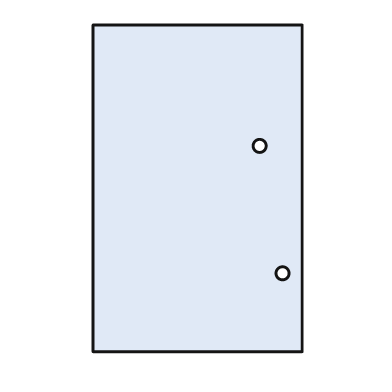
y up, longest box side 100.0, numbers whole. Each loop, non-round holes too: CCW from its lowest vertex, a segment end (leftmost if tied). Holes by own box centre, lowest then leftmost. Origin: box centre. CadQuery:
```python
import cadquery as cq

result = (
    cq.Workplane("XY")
    .moveTo(-32.0, -50.0)
    .lineTo(32.0, -50.0)
    .lineTo(32.0, 50.0)
    .lineTo(-32.0, 50.0)
    .close()
    .moveTo(26.0, -26.0)
    .circle(2.0)
    .moveTo(19.0, 13.0)
    .circle(2.0)
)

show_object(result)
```